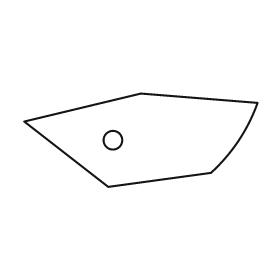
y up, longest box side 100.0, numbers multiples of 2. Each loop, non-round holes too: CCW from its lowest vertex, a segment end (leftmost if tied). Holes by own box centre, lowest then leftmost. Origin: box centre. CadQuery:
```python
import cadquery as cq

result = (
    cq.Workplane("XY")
    .moveTo(-14.0, -20.0)
    .lineTo(30.0, -14.0)
    .threePointArc((42.0, 0.0), (50.0, 16.0))
    .lineTo(0.0, 20.0)
    .lineTo(-50.0, 8.0)
    .close()
    .moveTo(-12.0, 0.0)
    .circle(4.0)
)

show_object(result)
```